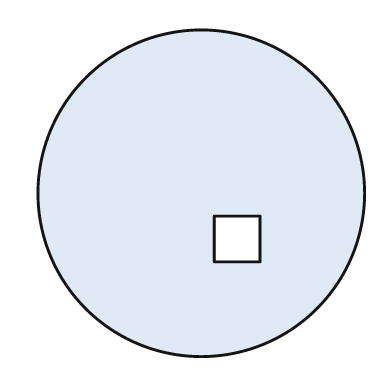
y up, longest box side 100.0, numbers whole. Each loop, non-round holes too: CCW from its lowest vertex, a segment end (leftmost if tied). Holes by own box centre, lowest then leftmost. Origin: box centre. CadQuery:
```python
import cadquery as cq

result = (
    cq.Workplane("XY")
    .moveTo(0.0, 0.0)
    .circle(50.0)
    .moveTo(4.0, -21.0)
    .lineTo(18.0, -21.0)
    .lineTo(18.0, -7.0)
    .lineTo(4.0, -7.0)
    .close()
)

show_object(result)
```